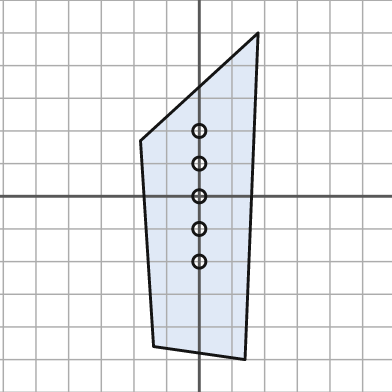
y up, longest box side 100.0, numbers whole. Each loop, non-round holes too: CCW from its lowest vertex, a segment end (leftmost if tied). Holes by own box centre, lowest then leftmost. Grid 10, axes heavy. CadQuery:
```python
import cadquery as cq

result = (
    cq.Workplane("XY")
    .moveTo(14.0, -50.0)
    .lineTo(18.0, 50.0)
    .lineTo(-18.0, 17.0)
    .lineTo(-14.0, -46.0)
    .close()
    .moveTo(0.0, -20.0)
    .circle(2.0)
    .moveTo(0.0, -10.0)
    .circle(2.0)
    .moveTo(0.0, 0.0)
    .circle(2.0)
    .moveTo(0.0, 10.0)
    .circle(2.0)
    .moveTo(0.0, 20.0)
    .circle(2.0)
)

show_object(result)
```